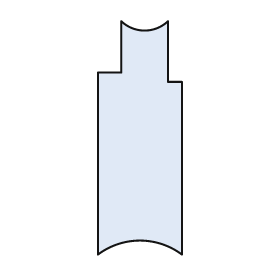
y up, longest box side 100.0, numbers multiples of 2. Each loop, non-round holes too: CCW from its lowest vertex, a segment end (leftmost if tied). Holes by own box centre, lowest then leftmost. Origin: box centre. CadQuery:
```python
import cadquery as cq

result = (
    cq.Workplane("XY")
    .moveTo(-18.0, -50.0)
    .threePointArc((0.0, -44.0), (18.0, -50.0))
    .lineTo(18.0, 24.0)
    .lineTo(12.0, 24.0)
    .lineTo(12.0, 50.0)
    .threePointArc((2.0, 46.0), (-8.0, 50.0))
    .lineTo(-8.0, 28.0)
    .lineTo(-18.0, 28.0)
    .close()
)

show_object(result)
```